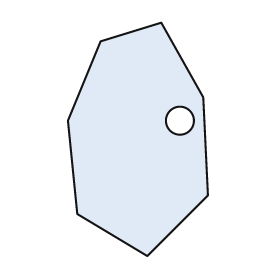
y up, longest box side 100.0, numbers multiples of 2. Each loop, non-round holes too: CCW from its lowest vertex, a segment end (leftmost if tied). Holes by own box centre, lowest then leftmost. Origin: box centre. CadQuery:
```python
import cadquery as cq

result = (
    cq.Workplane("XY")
    .moveTo(4.0, -50.0)
    .lineTo(30.0, -24.0)
    .lineTo(28.0, 18.0)
    .lineTo(10.0, 50.0)
    .lineTo(-16.0, 42.0)
    .lineTo(-30.0, 8.0)
    .lineTo(-26.0, -32.0)
    .close()
    .moveTo(18.0, 8.0)
    .circle(6.0)
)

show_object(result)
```